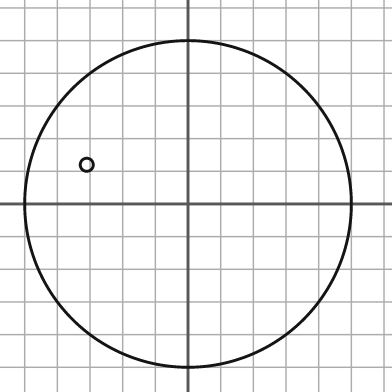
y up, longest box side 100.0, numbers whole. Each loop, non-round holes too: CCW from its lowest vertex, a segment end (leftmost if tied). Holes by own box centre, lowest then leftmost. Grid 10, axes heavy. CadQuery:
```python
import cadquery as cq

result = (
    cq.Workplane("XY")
    .moveTo(0.0, 0.0)
    .circle(50.0)
    .moveTo(-31.0, 12.0)
    .circle(2.0)
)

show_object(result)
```